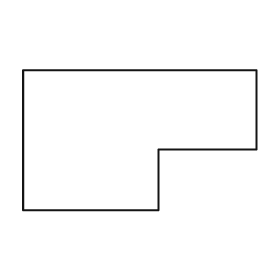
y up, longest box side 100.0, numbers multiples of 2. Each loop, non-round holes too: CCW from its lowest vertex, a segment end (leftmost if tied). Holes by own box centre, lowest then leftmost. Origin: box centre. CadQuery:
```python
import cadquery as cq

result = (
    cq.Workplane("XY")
    .moveTo(-50.0, -30.0)
    .lineTo(8.0, -30.0)
    .lineTo(8.0, -4.0)
    .lineTo(50.0, -4.0)
    .lineTo(50.0, 30.0)
    .lineTo(-50.0, 30.0)
    .close()
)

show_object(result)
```